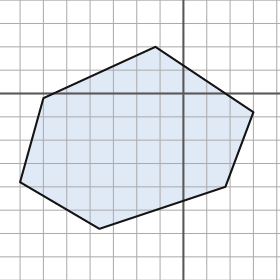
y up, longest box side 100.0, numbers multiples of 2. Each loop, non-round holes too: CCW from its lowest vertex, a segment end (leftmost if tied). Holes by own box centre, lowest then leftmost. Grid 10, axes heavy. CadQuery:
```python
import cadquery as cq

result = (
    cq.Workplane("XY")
    .moveTo(-36.0, -58.0)
    .lineTo(18.0, -40.0)
    .lineTo(30.0, -8.0)
    .lineTo(-12.0, 20.0)
    .lineTo(-60.0, -2.0)
    .lineTo(-70.0, -38.0)
    .close()
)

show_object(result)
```